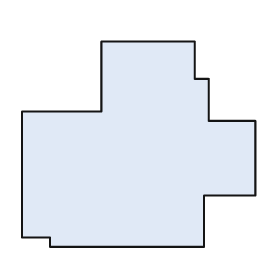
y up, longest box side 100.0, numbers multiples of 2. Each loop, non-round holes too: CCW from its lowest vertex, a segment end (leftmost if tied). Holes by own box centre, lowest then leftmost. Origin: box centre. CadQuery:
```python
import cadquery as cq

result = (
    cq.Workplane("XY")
    .moveTo(-38.0, -44.0)
    .lineTo(28.0, -44.0)
    .lineTo(28.0, -22.0)
    .lineTo(50.0, -22.0)
    .lineTo(50.0, 10.0)
    .lineTo(30.0, 10.0)
    .lineTo(30.0, 28.0)
    .lineTo(24.0, 28.0)
    .lineTo(24.0, 44.0)
    .lineTo(-16.0, 44.0)
    .lineTo(-16.0, 14.0)
    .lineTo(-50.0, 14.0)
    .lineTo(-50.0, -40.0)
    .lineTo(-38.0, -40.0)
    .close()
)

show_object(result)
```